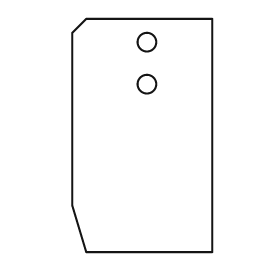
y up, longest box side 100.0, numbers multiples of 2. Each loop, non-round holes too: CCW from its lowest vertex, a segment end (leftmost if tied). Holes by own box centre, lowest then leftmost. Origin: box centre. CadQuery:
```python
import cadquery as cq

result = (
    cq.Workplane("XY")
    .moveTo(-24.0, -50.0)
    .lineTo(30.0, -50.0)
    .lineTo(30.0, 50.0)
    .lineTo(-24.0, 50.0)
    .lineTo(-30.0, 44.0)
    .lineTo(-30.0, -30.0)
    .close()
    .moveTo(2.0, 22.0)
    .circle(4.0)
    .moveTo(2.0, 40.0)
    .circle(4.0)
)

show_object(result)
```